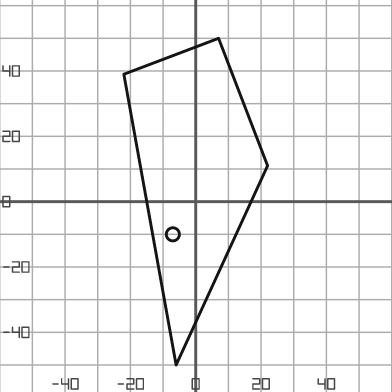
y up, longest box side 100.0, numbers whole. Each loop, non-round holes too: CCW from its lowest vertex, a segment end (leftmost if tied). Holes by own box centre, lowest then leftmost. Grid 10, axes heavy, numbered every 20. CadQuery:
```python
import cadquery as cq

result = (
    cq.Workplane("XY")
    .moveTo(-6.0, -50.0)
    .lineTo(22.0, 11.0)
    .lineTo(7.0, 50.0)
    .lineTo(-22.0, 39.0)
    .close()
    .moveTo(-7.0, -10.0)
    .circle(2.0)
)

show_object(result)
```